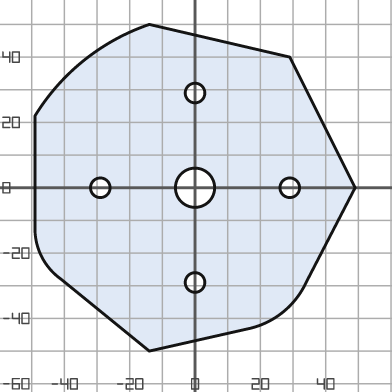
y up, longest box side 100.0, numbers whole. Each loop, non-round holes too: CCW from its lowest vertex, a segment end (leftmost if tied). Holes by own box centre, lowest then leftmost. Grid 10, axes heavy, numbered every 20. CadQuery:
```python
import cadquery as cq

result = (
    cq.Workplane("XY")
    .moveTo(-14.0, -50.0)
    .lineTo(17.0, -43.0)
    .threePointArc((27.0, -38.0), (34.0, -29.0))
    .lineTo(49.0, 0.0)
    .lineTo(29.0, 40.0)
    .lineTo(-14.0, 50.0)
    .threePointArc((-34.0, 39.0), (-49.0, 22.0))
    .lineTo(-49.0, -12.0)
    .threePointArc((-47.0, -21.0), (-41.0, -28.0))
    .close()
    .moveTo(0.0, -29.0)
    .circle(3.0)
    .moveTo(-29.0, 0.0)
    .circle(3.0)
    .moveTo(0.0, 0.0)
    .circle(6.0)
    .moveTo(29.0, 0.0)
    .circle(3.0)
    .moveTo(0.0, 29.0)
    .circle(3.0)
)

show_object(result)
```